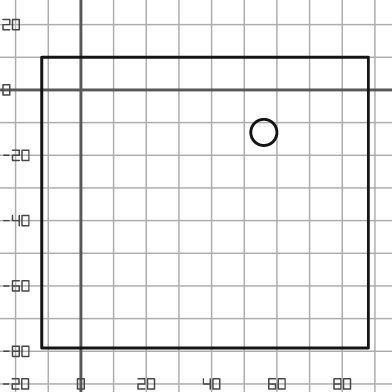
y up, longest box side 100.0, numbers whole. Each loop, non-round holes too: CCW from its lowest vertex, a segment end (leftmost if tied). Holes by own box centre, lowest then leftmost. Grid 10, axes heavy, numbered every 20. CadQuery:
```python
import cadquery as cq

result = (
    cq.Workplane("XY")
    .moveTo(-12.0, -79.0)
    .lineTo(88.0, -79.0)
    .lineTo(88.0, 10.0)
    .lineTo(-12.0, 10.0)
    .close()
    .moveTo(56.0, -13.0)
    .circle(4.0)
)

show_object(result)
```